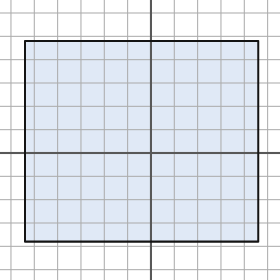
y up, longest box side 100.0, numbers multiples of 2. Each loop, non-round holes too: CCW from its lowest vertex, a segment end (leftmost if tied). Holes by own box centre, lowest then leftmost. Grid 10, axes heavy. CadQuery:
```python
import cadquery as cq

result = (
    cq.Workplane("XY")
    .moveTo(-54.0, -38.0)
    .lineTo(46.0, -38.0)
    .lineTo(46.0, 48.0)
    .lineTo(-54.0, 48.0)
    .close()
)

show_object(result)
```